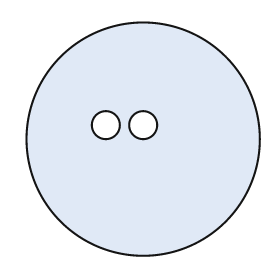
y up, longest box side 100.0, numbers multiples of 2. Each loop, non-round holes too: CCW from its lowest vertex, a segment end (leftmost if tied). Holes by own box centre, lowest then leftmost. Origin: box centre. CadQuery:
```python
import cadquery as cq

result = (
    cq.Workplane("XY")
    .moveTo(0.0, 0.0)
    .circle(50.0)
    .moveTo(-16.0, 6.0)
    .circle(6.0)
    .moveTo(0.0, 6.0)
    .circle(6.0)
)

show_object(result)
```